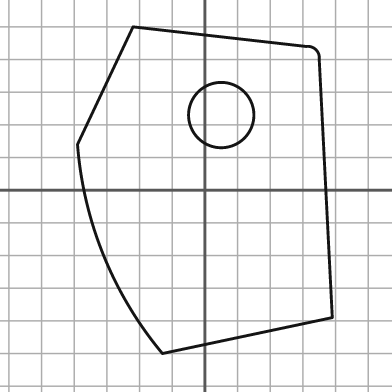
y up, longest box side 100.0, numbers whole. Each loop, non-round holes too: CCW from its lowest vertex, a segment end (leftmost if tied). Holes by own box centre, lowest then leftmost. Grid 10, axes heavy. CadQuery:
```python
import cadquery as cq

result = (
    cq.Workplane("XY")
    .moveTo(-13.0, -50.0)
    .lineTo(39.0, -39.0)
    .lineTo(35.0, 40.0)
    .threePointArc((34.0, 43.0), (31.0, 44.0))
    .lineTo(-22.0, 50.0)
    .lineTo(-39.0, 14.0)
    .threePointArc((-31.0, -20.0), (-13.0, -50.0))
    .close()
    .moveTo(5.0, 23.0)
    .circle(10.0)
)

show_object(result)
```